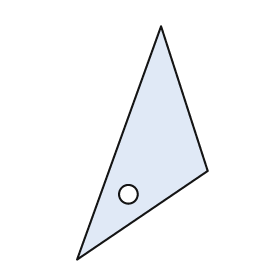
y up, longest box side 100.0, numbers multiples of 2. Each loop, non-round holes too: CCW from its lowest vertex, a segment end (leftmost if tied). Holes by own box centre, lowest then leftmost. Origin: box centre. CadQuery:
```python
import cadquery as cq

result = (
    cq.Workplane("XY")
    .moveTo(-28.0, -50.0)
    .lineTo(28.0, -12.0)
    .lineTo(8.0, 50.0)
    .close()
    .moveTo(-6.0, -22.0)
    .circle(4.0)
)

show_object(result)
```